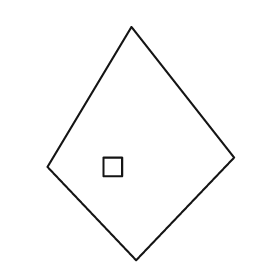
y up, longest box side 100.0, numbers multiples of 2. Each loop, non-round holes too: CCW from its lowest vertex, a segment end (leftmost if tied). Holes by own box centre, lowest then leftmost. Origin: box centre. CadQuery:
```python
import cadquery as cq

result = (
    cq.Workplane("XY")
    .moveTo(-2.0, -50.0)
    .lineTo(40.0, -6.0)
    .lineTo(-4.0, 50.0)
    .lineTo(-40.0, -10.0)
    .close()
    .moveTo(-16.0, -14.0)
    .lineTo(-8.0, -14.0)
    .lineTo(-8.0, -6.0)
    .lineTo(-16.0, -6.0)
    .close()
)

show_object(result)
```